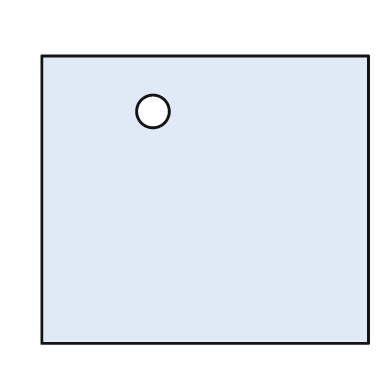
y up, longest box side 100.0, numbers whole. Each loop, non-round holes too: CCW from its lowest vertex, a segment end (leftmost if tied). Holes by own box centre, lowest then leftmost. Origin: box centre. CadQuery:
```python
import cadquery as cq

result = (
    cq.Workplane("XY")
    .moveTo(-50.0, -44.0)
    .lineTo(50.0, -44.0)
    .lineTo(50.0, 44.0)
    .lineTo(-50.0, 44.0)
    .close()
    .moveTo(-16.0, 27.0)
    .circle(5.0)
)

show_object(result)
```